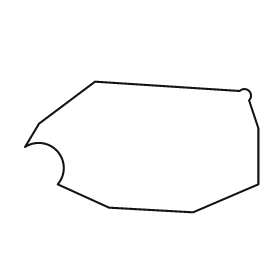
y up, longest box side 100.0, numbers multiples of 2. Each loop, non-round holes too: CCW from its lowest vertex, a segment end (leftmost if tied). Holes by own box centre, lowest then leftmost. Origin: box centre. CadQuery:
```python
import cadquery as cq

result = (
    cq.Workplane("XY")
    .moveTo(22.0, -28.0)
    .lineTo(50.0, -16.0)
    .lineTo(50.0, 8.0)
    .lineTo(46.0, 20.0)
    .threePointArc((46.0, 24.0), (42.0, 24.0))
    .lineTo(-20.0, 28.0)
    .lineTo(-44.0, 10.0)
    .lineTo(-50.0, 0.0)
    .threePointArc((-36.0, -2.0), (-36.0, -16.0))
    .lineTo(-14.0, -26.0)
    .close()
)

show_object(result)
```